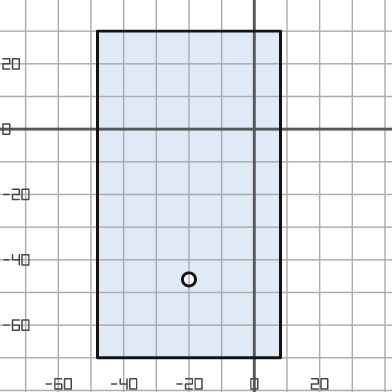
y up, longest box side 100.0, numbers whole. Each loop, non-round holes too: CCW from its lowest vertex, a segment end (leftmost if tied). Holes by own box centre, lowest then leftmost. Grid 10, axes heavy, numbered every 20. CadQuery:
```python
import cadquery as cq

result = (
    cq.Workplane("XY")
    .moveTo(-48.0, -70.0)
    .lineTo(8.0, -70.0)
    .lineTo(8.0, 30.0)
    .lineTo(-48.0, 30.0)
    .close()
    .moveTo(-20.0, -46.0)
    .circle(2.0)
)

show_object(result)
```